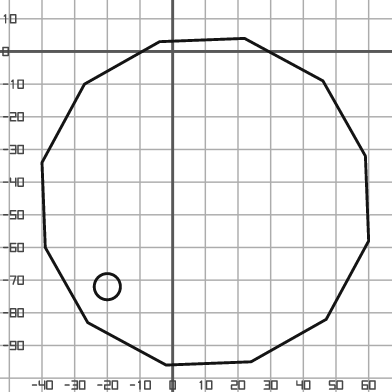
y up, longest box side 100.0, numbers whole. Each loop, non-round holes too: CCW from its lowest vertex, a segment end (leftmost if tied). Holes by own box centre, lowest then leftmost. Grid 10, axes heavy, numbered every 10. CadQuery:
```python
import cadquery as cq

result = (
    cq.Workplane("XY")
    .moveTo(-2.0, -96.0)
    .lineTo(24.0, -95.0)
    .lineTo(47.0, -82.0)
    .lineTo(60.0, -58.0)
    .lineTo(59.0, -32.0)
    .lineTo(46.0, -9.0)
    .lineTo(22.0, 4.0)
    .lineTo(-4.0, 3.0)
    .lineTo(-27.0, -10.0)
    .lineTo(-40.0, -34.0)
    .lineTo(-39.0, -60.0)
    .lineTo(-26.0, -83.0)
    .close()
    .moveTo(-20.0, -72.0)
    .circle(4.0)
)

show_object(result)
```